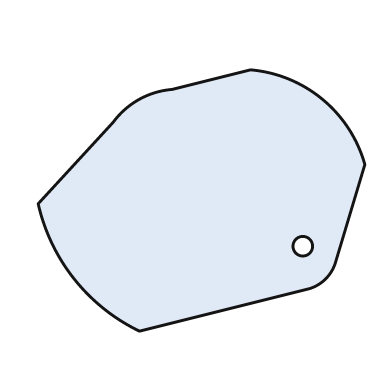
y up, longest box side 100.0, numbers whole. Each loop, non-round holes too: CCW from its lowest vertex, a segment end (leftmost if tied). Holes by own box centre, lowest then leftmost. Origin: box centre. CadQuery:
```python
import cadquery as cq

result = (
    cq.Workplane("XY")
    .moveTo(-19.0, -40.0)
    .lineTo(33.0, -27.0)
    .threePointArc((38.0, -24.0), (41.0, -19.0))
    .lineTo(50.0, 11.0)
    .threePointArc((37.0, 31.0), (15.0, 40.0))
    .lineTo(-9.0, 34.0)
    .threePointArc((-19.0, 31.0), (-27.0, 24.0))
    .lineTo(-50.0, -1.0)
    .threePointArc((-39.0, -24.0), (-19.0, -40.0))
    .close()
    .moveTo(31.0, -14.0)
    .circle(3.0)
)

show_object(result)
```